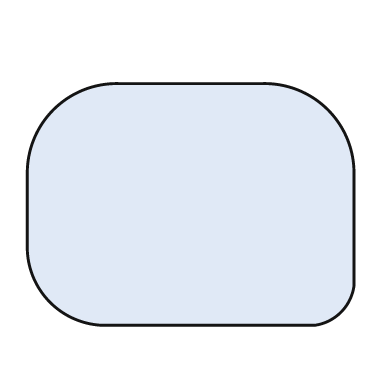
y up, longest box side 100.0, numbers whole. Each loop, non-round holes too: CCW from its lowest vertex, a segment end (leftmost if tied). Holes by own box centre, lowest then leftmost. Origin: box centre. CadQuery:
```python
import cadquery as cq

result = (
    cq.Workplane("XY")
    .moveTo(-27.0, -37.0)
    .lineTo(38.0, -37.0)
    .threePointArc((46.0, -33.0), (50.0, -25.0))
    .lineTo(50.0, 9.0)
    .threePointArc((42.0, 29.0), (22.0, 37.0))
    .lineTo(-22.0, 37.0)
    .threePointArc((-42.0, 29.0), (-50.0, 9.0))
    .lineTo(-50.0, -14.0)
    .threePointArc((-43.0, -30.0), (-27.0, -37.0))
    .close()
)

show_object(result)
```